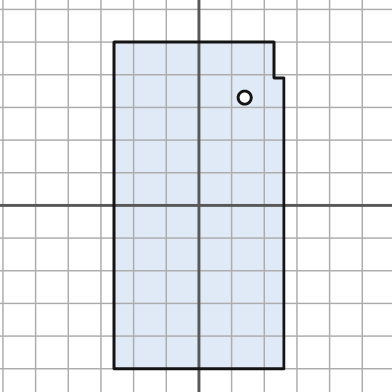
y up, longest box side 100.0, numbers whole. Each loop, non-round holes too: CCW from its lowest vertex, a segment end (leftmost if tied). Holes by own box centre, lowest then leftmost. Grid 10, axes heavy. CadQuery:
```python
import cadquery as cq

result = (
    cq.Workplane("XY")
    .moveTo(-26.0, -50.0)
    .lineTo(26.0, -50.0)
    .lineTo(26.0, 39.0)
    .lineTo(23.0, 39.0)
    .lineTo(23.0, 50.0)
    .lineTo(-26.0, 50.0)
    .close()
    .moveTo(14.0, 33.0)
    .circle(2.0)
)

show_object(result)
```